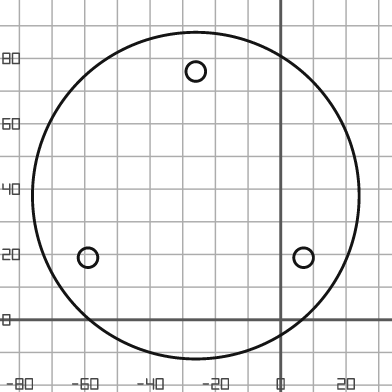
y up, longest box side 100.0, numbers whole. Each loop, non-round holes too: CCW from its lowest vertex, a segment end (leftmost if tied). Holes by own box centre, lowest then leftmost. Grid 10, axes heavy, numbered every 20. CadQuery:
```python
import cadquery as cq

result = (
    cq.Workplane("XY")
    .moveTo(-26.0, 38.0)
    .circle(50.0)
    .moveTo(-59.0, 19.0)
    .circle(3.0)
    .moveTo(7.0, 19.0)
    .circle(3.0)
    .moveTo(-26.0, 76.0)
    .circle(3.0)
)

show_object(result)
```